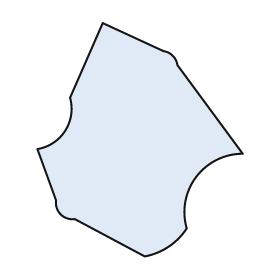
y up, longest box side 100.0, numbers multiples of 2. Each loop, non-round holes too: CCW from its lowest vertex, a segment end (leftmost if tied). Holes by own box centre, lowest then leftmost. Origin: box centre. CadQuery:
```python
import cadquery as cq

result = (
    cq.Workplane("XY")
    .moveTo(2.0, -50.0)
    .threePointArc((12.0, -46.0), (20.0, -38.0))
    .threePointArc((24.0, -16.0), (44.0, -6.0))
    .lineTo(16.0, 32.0)
    .threePointArc((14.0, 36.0), (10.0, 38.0))
    .lineTo(-16.0, 50.0)
    .lineTo(-30.0, 18.0)
    .threePointArc((-32.0, 4.0), (-44.0, -4.0))
    .lineTo(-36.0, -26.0)
    .threePointArc((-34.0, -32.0), (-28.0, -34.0))
    .close()
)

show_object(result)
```